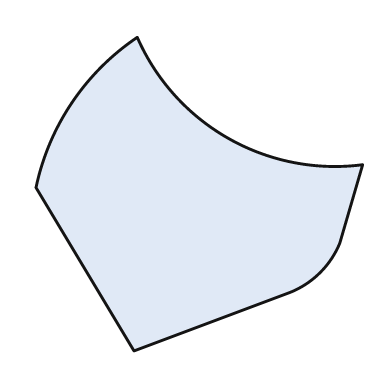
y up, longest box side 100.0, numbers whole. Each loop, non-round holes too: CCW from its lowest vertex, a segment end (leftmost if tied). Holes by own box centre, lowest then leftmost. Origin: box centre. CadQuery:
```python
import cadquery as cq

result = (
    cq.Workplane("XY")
    .moveTo(-20.0, -48.0)
    .lineTo(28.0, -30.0)
    .threePointArc((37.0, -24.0), (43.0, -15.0))
    .lineTo(50.0, 9.0)
    .threePointArc((9.0, 17.0), (-19.0, 48.0))
    .threePointArc((-39.0, 28.0), (-50.0, 2.0))
    .close()
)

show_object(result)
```